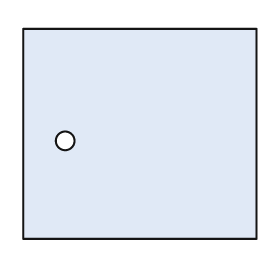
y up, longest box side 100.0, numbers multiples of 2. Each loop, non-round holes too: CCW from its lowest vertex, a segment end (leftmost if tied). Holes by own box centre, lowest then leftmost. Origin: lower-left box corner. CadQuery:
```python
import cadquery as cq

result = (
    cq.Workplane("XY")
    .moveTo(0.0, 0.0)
    .lineTo(100.0, 0.0)
    .lineTo(100.0, 90.0)
    .lineTo(0.0, 90.0)
    .close()
    .moveTo(18.0, 42.0)
    .circle(4.0)
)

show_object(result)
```